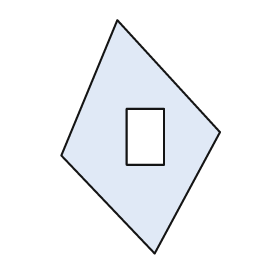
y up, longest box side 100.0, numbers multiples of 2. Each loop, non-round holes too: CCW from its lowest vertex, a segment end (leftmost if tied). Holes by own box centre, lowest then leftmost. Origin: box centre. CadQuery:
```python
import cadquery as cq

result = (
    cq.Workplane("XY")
    .moveTo(6.0, -50.0)
    .lineTo(34.0, 2.0)
    .lineTo(-10.0, 50.0)
    .lineTo(-34.0, -8.0)
    .close()
    .moveTo(-6.0, -12.0)
    .lineTo(10.0, -12.0)
    .lineTo(10.0, 12.0)
    .lineTo(-6.0, 12.0)
    .close()
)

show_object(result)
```